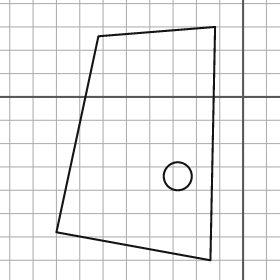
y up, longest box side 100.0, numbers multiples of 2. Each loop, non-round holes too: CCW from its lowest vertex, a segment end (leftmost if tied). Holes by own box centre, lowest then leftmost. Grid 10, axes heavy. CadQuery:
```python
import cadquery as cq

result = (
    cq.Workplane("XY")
    .moveTo(-14.0, -70.0)
    .lineTo(-12.0, 30.0)
    .lineTo(-62.0, 26.0)
    .lineTo(-80.0, -58.0)
    .close()
    .moveTo(-28.0, -34.0)
    .circle(6.0)
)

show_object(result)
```